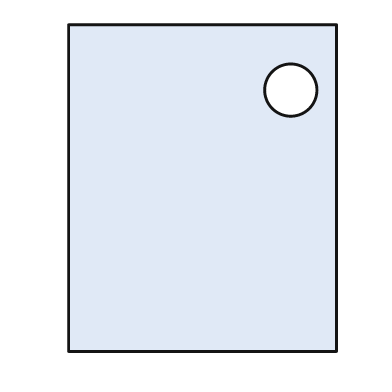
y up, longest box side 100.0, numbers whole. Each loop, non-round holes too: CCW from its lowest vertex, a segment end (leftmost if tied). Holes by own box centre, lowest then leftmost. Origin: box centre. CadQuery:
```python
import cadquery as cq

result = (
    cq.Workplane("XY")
    .moveTo(-41.0, -50.0)
    .lineTo(41.0, -50.0)
    .lineTo(41.0, 50.0)
    .lineTo(-41.0, 50.0)
    .close()
    .moveTo(27.0, 30.0)
    .circle(8.0)
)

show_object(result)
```